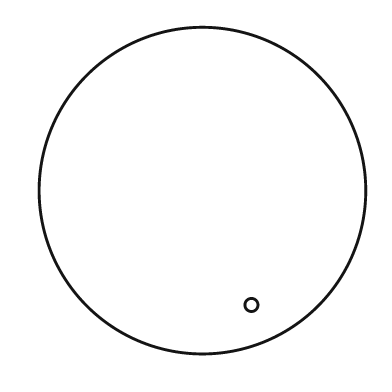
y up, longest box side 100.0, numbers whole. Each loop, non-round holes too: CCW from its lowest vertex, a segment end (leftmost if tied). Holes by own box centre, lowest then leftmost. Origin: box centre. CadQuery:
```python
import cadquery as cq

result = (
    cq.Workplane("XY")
    .moveTo(0.0, 0.0)
    .circle(50.0)
    .moveTo(15.0, -35.0)
    .circle(2.0)
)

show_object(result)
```